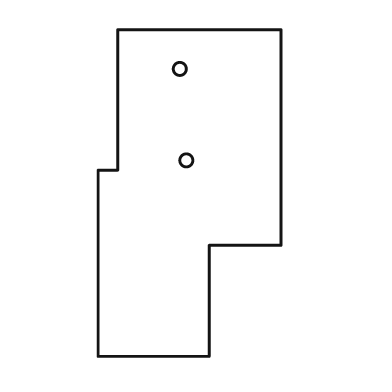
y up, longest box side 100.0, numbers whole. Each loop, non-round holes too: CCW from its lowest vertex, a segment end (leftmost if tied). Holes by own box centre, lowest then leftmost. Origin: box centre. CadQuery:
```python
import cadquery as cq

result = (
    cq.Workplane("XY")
    .moveTo(-28.0, -50.0)
    .lineTo(6.0, -50.0)
    .lineTo(6.0, -16.0)
    .lineTo(28.0, -16.0)
    .lineTo(28.0, 50.0)
    .lineTo(-22.0, 50.0)
    .lineTo(-22.0, 7.0)
    .lineTo(-28.0, 7.0)
    .close()
    .moveTo(-1.0, 10.0)
    .circle(2.0)
    .moveTo(-3.0, 38.0)
    .circle(2.0)
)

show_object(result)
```